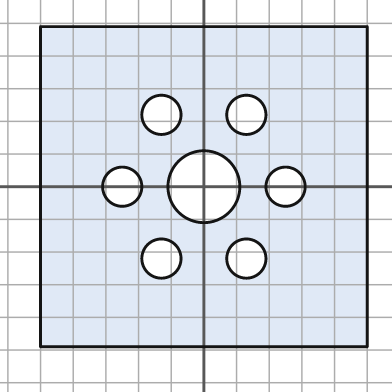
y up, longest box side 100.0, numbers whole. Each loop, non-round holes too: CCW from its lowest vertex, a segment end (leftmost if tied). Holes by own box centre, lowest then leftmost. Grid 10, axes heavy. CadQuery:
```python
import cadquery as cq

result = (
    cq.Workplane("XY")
    .moveTo(-50.0, -49.0)
    .lineTo(50.0, -49.0)
    .lineTo(50.0, 49.0)
    .lineTo(-50.0, 49.0)
    .close()
    .moveTo(-13.0, -22.0)
    .circle(6.0)
    .moveTo(13.0, -22.0)
    .circle(6.0)
    .moveTo(-25.0, 0.0)
    .circle(6.0)
    .moveTo(0.0, 0.0)
    .circle(11.0)
    .moveTo(25.0, 0.0)
    .circle(6.0)
    .moveTo(-13.0, 22.0)
    .circle(6.0)
    .moveTo(13.0, 22.0)
    .circle(6.0)
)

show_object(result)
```